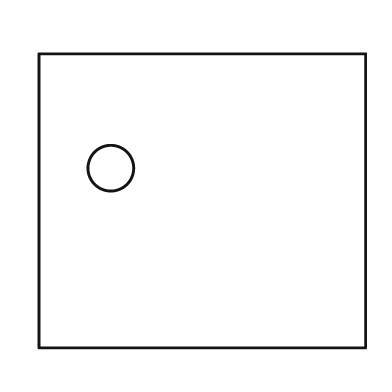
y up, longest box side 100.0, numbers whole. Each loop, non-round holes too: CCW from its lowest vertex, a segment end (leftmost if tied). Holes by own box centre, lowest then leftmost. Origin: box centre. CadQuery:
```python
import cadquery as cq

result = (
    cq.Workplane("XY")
    .moveTo(-50.0, -45.0)
    .lineTo(50.0, -45.0)
    .lineTo(50.0, 45.0)
    .lineTo(-50.0, 45.0)
    .close()
    .moveTo(-28.0, 10.0)
    .circle(7.0)
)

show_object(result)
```